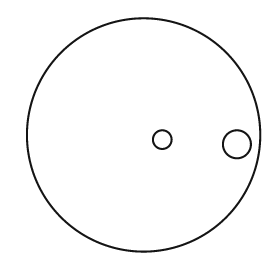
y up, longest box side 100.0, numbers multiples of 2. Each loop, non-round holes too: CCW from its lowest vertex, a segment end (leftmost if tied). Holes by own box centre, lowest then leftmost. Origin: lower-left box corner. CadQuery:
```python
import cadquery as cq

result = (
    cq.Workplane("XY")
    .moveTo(50.0, 50.0)
    .circle(50.0)
    .moveTo(90.0, 46.0)
    .circle(6.0)
    .moveTo(58.0, 48.0)
    .circle(4.0)
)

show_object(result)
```